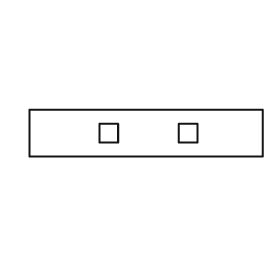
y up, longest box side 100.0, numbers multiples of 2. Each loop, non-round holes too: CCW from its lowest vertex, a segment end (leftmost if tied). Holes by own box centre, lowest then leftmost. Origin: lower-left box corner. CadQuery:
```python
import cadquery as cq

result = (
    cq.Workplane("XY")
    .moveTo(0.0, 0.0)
    .lineTo(100.0, 0.0)
    .lineTo(100.0, 20.0)
    .lineTo(0.0, 20.0)
    .close()
    .moveTo(30.0, 6.0)
    .lineTo(38.0, 6.0)
    .lineTo(38.0, 14.0)
    .lineTo(30.0, 14.0)
    .close()
    .moveTo(64.0, 6.0)
    .lineTo(72.0, 6.0)
    .lineTo(72.0, 14.0)
    .lineTo(64.0, 14.0)
    .close()
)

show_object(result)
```